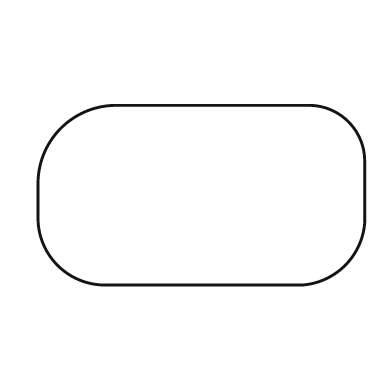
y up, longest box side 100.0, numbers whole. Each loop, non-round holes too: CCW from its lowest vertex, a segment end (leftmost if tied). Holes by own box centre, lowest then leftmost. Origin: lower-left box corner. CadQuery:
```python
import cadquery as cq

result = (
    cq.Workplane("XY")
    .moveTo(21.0, 0.0)
    .lineTo(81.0, 0.0)
    .threePointArc((94.0, 6.0), (100.0, 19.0))
    .lineTo(100.0, 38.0)
    .threePointArc((95.0, 50.0), (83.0, 55.0))
    .lineTo(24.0, 55.0)
    .threePointArc((7.0, 48.0), (0.0, 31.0))
    .lineTo(0.0, 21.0)
    .threePointArc((6.0, 6.0), (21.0, 0.0))
    .close()
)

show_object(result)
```